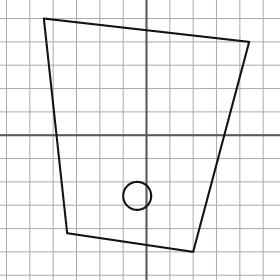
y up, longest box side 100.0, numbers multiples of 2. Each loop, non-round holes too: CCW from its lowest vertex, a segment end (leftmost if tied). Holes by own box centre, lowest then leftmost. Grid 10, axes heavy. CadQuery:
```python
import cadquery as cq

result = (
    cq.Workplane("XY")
    .moveTo(20.0, -50.0)
    .lineTo(44.0, 40.0)
    .lineTo(-44.0, 50.0)
    .lineTo(-34.0, -42.0)
    .close()
    .moveTo(-4.0, -26.0)
    .circle(6.0)
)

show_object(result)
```